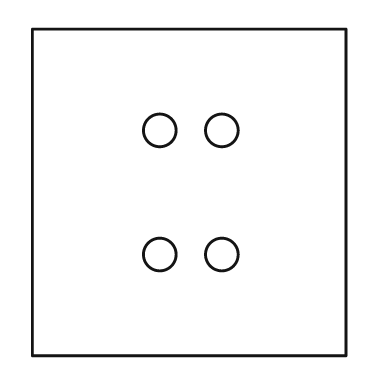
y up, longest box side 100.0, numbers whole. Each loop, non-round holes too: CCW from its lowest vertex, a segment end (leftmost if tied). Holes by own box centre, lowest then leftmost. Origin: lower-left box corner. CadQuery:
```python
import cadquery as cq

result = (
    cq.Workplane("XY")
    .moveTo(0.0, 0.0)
    .lineTo(96.0, 0.0)
    .lineTo(96.0, 100.0)
    .lineTo(0.0, 100.0)
    .close()
    .moveTo(39.0, 31.0)
    .circle(5.0)
    .moveTo(58.0, 31.0)
    .circle(5.0)
    .moveTo(39.0, 69.0)
    .circle(5.0)
    .moveTo(58.0, 69.0)
    .circle(5.0)
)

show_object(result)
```